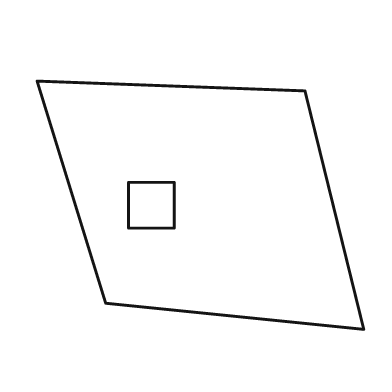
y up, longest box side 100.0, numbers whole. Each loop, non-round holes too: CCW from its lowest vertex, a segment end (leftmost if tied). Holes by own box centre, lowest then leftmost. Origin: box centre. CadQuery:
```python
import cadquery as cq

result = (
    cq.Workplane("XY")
    .moveTo(50.0, -38.0)
    .lineTo(32.0, 35.0)
    .lineTo(-50.0, 38.0)
    .lineTo(-29.0, -30.0)
    .close()
    .moveTo(-22.0, -7.0)
    .lineTo(-8.0, -7.0)
    .lineTo(-8.0, 7.0)
    .lineTo(-22.0, 7.0)
    .close()
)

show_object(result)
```